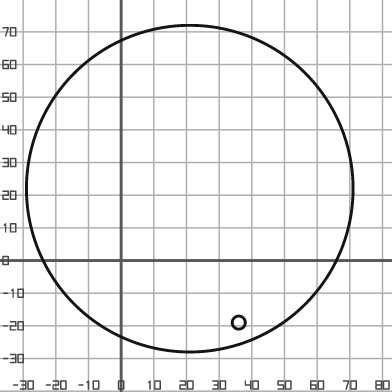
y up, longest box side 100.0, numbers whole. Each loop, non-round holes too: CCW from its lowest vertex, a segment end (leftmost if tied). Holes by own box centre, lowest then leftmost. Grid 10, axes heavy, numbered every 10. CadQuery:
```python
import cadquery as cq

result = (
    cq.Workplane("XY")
    .moveTo(21.0, 22.0)
    .circle(50.0)
    .moveTo(36.0, -19.0)
    .circle(2.0)
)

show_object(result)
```